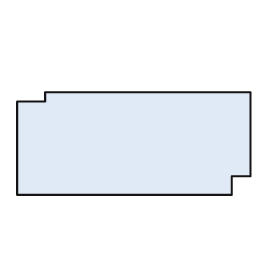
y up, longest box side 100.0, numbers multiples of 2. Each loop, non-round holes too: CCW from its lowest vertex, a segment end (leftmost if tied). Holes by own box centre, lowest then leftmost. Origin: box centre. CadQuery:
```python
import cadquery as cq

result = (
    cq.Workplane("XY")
    .moveTo(-50.0, -22.0)
    .lineTo(42.0, -22.0)
    .lineTo(42.0, -14.0)
    .lineTo(50.0, -14.0)
    .lineTo(50.0, 22.0)
    .lineTo(-38.0, 22.0)
    .lineTo(-38.0, 18.0)
    .lineTo(-50.0, 18.0)
    .close()
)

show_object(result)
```